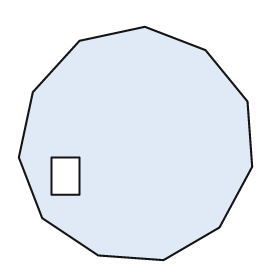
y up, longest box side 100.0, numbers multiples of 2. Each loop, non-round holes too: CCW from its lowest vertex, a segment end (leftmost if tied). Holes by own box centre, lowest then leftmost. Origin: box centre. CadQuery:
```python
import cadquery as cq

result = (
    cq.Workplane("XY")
    .moveTo(12.0, -50.0)
    .lineTo(36.0, -36.0)
    .lineTo(50.0, -10.0)
    .lineTo(48.0, 18.0)
    .lineTo(30.0, 40.0)
    .lineTo(4.0, 50.0)
    .lineTo(-24.0, 44.0)
    .lineTo(-44.0, 22.0)
    .lineTo(-50.0, -6.0)
    .lineTo(-40.0, -32.0)
    .lineTo(-16.0, -48.0)
    .close()
    .moveTo(-36.0, -22.0)
    .lineTo(-24.0, -22.0)
    .lineTo(-24.0, -6.0)
    .lineTo(-36.0, -6.0)
    .close()
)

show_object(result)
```